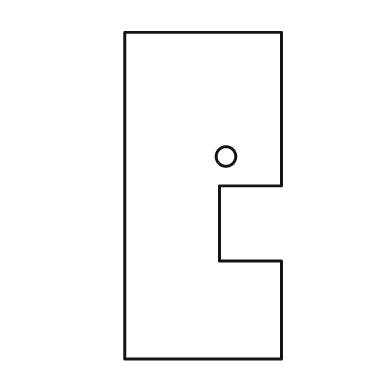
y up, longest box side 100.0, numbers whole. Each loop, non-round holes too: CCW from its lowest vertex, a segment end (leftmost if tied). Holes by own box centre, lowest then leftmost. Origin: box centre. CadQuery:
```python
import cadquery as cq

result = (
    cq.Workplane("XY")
    .moveTo(-24.0, -50.0)
    .lineTo(24.0, -50.0)
    .lineTo(24.0, -20.0)
    .lineTo(5.0, -20.0)
    .lineTo(5.0, 3.0)
    .lineTo(24.0, 3.0)
    .lineTo(24.0, 50.0)
    .lineTo(-24.0, 50.0)
    .close()
    .moveTo(7.0, 12.0)
    .circle(3.0)
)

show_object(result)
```